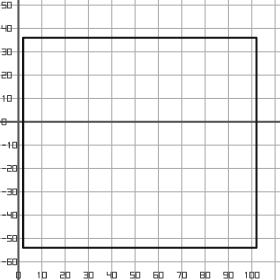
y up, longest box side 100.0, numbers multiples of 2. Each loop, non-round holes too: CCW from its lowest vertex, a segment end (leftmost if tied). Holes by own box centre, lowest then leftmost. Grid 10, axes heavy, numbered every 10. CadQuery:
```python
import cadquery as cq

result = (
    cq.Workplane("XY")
    .moveTo(2.0, -54.0)
    .lineTo(102.0, -54.0)
    .lineTo(102.0, 36.0)
    .lineTo(2.0, 36.0)
    .close()
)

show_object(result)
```